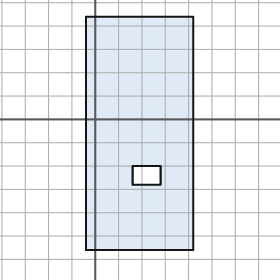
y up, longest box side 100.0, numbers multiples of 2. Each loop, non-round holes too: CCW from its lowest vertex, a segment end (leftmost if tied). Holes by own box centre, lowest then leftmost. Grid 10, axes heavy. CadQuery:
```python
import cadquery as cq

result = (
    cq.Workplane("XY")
    .moveTo(-4.0, -56.0)
    .lineTo(42.0, -56.0)
    .lineTo(42.0, 44.0)
    .lineTo(-4.0, 44.0)
    .close()
    .moveTo(16.0, -28.0)
    .lineTo(28.0, -28.0)
    .lineTo(28.0, -20.0)
    .lineTo(16.0, -20.0)
    .close()
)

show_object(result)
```